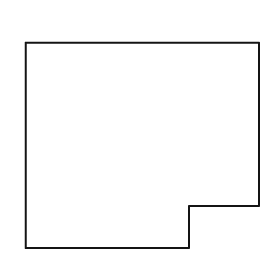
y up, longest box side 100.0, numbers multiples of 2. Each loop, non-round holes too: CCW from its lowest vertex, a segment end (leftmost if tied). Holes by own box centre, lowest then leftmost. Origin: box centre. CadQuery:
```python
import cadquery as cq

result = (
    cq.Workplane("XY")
    .moveTo(-50.0, -44.0)
    .lineTo(20.0, -44.0)
    .lineTo(20.0, -26.0)
    .lineTo(50.0, -26.0)
    .lineTo(50.0, 44.0)
    .lineTo(-50.0, 44.0)
    .close()
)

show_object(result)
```